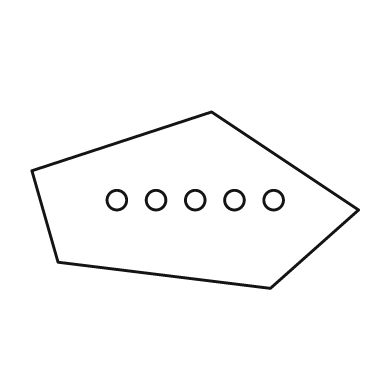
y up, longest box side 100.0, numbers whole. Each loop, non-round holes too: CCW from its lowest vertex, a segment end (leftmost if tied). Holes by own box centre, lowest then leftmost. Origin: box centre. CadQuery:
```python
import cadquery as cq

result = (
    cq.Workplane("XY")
    .moveTo(23.0, -27.0)
    .lineTo(50.0, -3.0)
    .lineTo(5.0, 27.0)
    .lineTo(-50.0, 9.0)
    .lineTo(-42.0, -19.0)
    .close()
    .moveTo(-24.0, 0.0)
    .circle(3.0)
    .moveTo(-12.0, 0.0)
    .circle(3.0)
    .moveTo(0.0, 0.0)
    .circle(3.0)
    .moveTo(12.0, 0.0)
    .circle(3.0)
    .moveTo(24.0, 0.0)
    .circle(3.0)
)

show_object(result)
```